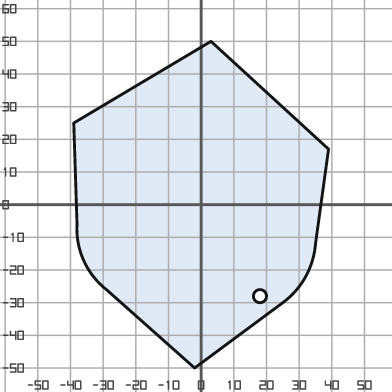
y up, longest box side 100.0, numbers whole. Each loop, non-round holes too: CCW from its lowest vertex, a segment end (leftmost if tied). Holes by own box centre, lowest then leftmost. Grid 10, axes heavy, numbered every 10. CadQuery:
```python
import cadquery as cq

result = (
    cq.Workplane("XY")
    .moveTo(-2.0, -50.0)
    .lineTo(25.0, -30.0)
    .threePointArc((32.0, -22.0), (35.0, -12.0))
    .lineTo(39.0, 17.0)
    .lineTo(3.0, 50.0)
    .lineTo(-39.0, 25.0)
    .lineTo(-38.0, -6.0)
    .threePointArc((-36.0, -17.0), (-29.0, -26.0))
    .close()
    .moveTo(18.0, -28.0)
    .circle(2.0)
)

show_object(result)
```